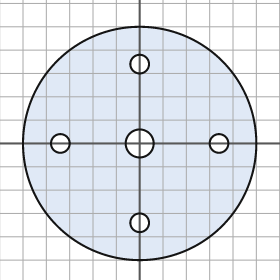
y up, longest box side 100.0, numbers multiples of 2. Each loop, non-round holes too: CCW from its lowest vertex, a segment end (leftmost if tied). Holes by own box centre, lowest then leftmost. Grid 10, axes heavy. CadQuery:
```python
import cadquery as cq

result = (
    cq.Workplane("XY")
    .moveTo(0.0, 0.0)
    .circle(50.0)
    .moveTo(0.0, -34.0)
    .circle(4.0)
    .moveTo(-34.0, 0.0)
    .circle(4.0)
    .moveTo(0.0, 0.0)
    .circle(6.0)
    .moveTo(34.0, 0.0)
    .circle(4.0)
    .moveTo(0.0, 34.0)
    .circle(4.0)
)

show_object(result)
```